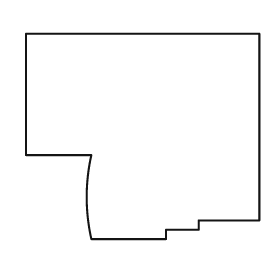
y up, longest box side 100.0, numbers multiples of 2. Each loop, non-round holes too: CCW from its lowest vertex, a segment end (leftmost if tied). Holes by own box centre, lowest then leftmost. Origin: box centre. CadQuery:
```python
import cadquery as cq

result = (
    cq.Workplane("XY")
    .moveTo(-22.0, -44.0)
    .lineTo(10.0, -44.0)
    .lineTo(10.0, -40.0)
    .lineTo(24.0, -40.0)
    .lineTo(24.0, -36.0)
    .lineTo(50.0, -36.0)
    .lineTo(50.0, 44.0)
    .lineTo(-50.0, 44.0)
    .lineTo(-50.0, -8.0)
    .lineTo(-22.0, -8.0)
    .threePointArc((-24.0, -26.0), (-22.0, -44.0))
    .close()
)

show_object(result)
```